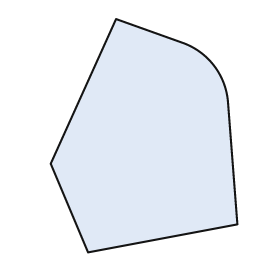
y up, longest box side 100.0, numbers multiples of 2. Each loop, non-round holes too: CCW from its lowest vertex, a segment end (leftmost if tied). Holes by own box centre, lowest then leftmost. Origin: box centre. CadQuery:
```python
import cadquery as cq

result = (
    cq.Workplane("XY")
    .moveTo(-24.0, -50.0)
    .lineTo(40.0, -38.0)
    .lineTo(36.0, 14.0)
    .threePointArc((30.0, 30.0), (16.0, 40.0))
    .lineTo(-12.0, 50.0)
    .lineTo(-40.0, -12.0)
    .close()
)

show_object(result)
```